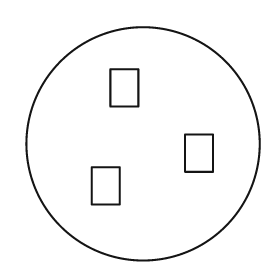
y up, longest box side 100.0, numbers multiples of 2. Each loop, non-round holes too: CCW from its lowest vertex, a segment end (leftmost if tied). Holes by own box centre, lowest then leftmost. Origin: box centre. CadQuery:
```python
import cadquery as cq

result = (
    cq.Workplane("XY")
    .moveTo(0.0, 0.0)
    .circle(50.0)
    .moveTo(-22.0, -26.0)
    .lineTo(-10.0, -26.0)
    .lineTo(-10.0, -10.0)
    .lineTo(-22.0, -10.0)
    .close()
    .moveTo(18.0, -12.0)
    .lineTo(30.0, -12.0)
    .lineTo(30.0, 4.0)
    .lineTo(18.0, 4.0)
    .close()
    .moveTo(-14.0, 16.0)
    .lineTo(-2.0, 16.0)
    .lineTo(-2.0, 32.0)
    .lineTo(-14.0, 32.0)
    .close()
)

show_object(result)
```